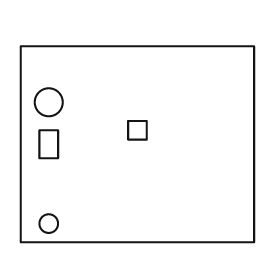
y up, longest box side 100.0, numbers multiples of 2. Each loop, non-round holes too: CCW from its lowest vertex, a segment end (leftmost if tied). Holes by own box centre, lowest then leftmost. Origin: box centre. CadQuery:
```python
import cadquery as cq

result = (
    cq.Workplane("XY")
    .moveTo(-50.0, -42.0)
    .lineTo(50.0, -42.0)
    .lineTo(50.0, 42.0)
    .lineTo(-50.0, 42.0)
    .close()
    .moveTo(-38.0, -34.0)
    .circle(4.0)
    .moveTo(-42.0, -6.0)
    .lineTo(-34.0, -6.0)
    .lineTo(-34.0, 6.0)
    .lineTo(-42.0, 6.0)
    .close()
    .moveTo(-4.0, 2.0)
    .lineTo(4.0, 2.0)
    .lineTo(4.0, 10.0)
    .lineTo(-4.0, 10.0)
    .close()
    .moveTo(-38.0, 18.0)
    .circle(6.0)
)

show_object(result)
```